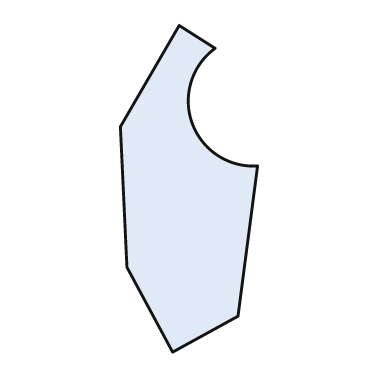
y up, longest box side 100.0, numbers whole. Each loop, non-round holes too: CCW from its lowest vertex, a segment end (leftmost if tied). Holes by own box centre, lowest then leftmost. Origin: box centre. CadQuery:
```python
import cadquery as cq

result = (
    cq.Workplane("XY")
    .moveTo(-5.0, -50.0)
    .lineTo(15.0, -39.0)
    .lineTo(21.0, 7.0)
    .threePointArc((1.0, 20.0), (8.0, 43.0))
    .lineTo(-3.0, 50.0)
    .lineTo(-21.0, 19.0)
    .lineTo(-19.0, -24.0)
    .close()
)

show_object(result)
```